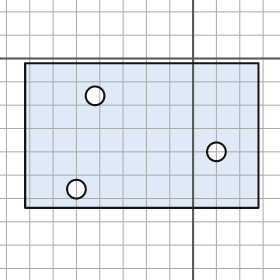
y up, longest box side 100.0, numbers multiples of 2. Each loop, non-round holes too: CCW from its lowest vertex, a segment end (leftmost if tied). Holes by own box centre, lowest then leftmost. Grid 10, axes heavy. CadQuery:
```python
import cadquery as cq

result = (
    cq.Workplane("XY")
    .moveTo(-72.0, -64.0)
    .lineTo(28.0, -64.0)
    .lineTo(28.0, -2.0)
    .lineTo(-72.0, -2.0)
    .close()
    .moveTo(-50.0, -56.0)
    .circle(4.0)
    .moveTo(10.0, -40.0)
    .circle(4.0)
    .moveTo(-42.0, -16.0)
    .circle(4.0)
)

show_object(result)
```